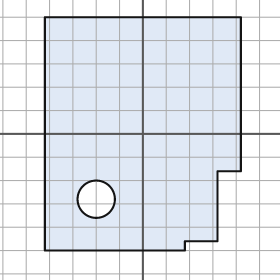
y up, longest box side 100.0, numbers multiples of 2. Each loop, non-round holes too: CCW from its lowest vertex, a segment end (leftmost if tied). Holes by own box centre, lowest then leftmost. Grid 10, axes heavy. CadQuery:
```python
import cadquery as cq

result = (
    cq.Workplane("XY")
    .moveTo(-42.0, -50.0)
    .lineTo(18.0, -50.0)
    .lineTo(18.0, -46.0)
    .lineTo(32.0, -46.0)
    .lineTo(32.0, -16.0)
    .lineTo(42.0, -16.0)
    .lineTo(42.0, 50.0)
    .lineTo(-42.0, 50.0)
    .close()
    .moveTo(-20.0, -28.0)
    .circle(8.0)
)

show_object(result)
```